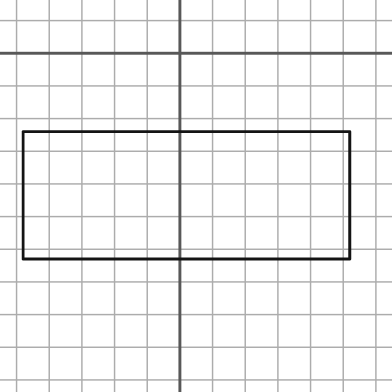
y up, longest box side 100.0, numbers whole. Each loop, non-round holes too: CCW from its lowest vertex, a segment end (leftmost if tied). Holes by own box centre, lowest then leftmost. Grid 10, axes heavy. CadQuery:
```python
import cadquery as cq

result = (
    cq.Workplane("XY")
    .moveTo(-48.0, -63.0)
    .lineTo(52.0, -63.0)
    .lineTo(52.0, -24.0)
    .lineTo(-48.0, -24.0)
    .close()
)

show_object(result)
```